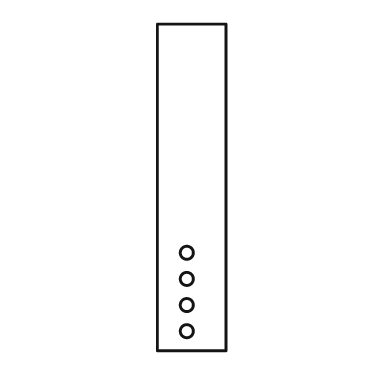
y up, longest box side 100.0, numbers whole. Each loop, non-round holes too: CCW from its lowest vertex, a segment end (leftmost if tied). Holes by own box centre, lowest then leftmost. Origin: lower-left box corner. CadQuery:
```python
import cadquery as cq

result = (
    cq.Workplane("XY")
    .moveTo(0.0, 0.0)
    .lineTo(21.0, 0.0)
    .lineTo(21.0, 100.0)
    .lineTo(0.0, 100.0)
    .close()
    .moveTo(9.0, 6.0)
    .circle(2.0)
    .moveTo(9.0, 14.0)
    .circle(2.0)
    .moveTo(9.0, 22.0)
    .circle(2.0)
    .moveTo(9.0, 30.0)
    .circle(2.0)
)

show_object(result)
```